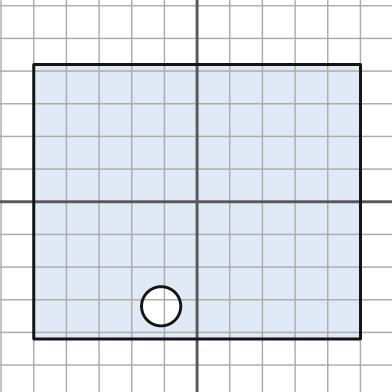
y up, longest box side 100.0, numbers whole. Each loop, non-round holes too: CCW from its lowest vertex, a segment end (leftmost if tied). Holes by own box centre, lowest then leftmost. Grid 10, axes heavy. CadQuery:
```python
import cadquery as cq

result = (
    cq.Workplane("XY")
    .moveTo(-50.0, -42.0)
    .lineTo(50.0, -42.0)
    .lineTo(50.0, 42.0)
    .lineTo(-50.0, 42.0)
    .close()
    .moveTo(-11.0, -32.0)
    .circle(6.0)
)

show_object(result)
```